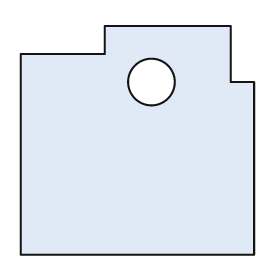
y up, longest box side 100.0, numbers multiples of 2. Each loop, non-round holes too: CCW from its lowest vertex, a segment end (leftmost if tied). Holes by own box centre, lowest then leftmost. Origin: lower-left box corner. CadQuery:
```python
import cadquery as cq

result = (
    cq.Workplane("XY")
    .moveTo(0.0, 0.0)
    .lineTo(100.0, 0.0)
    .lineTo(100.0, 74.0)
    .lineTo(90.0, 74.0)
    .lineTo(90.0, 98.0)
    .lineTo(36.0, 98.0)
    .lineTo(36.0, 86.0)
    .lineTo(0.0, 86.0)
    .close()
    .moveTo(56.0, 74.0)
    .circle(10.0)
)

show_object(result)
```